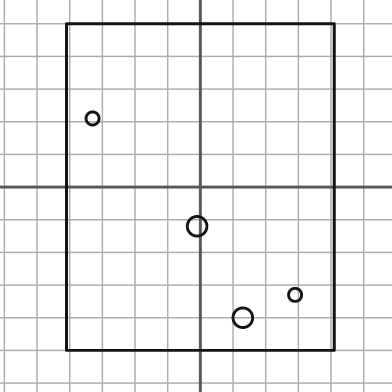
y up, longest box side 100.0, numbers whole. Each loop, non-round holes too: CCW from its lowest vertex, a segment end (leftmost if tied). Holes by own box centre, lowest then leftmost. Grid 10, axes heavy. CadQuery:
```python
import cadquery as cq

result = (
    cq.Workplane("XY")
    .moveTo(-41.0, -50.0)
    .lineTo(41.0, -50.0)
    .lineTo(41.0, 50.0)
    .lineTo(-41.0, 50.0)
    .close()
    .moveTo(13.0, -40.0)
    .circle(3.0)
    .moveTo(29.0, -33.0)
    .circle(2.0)
    .moveTo(-1.0, -12.0)
    .circle(3.0)
    .moveTo(-33.0, 21.0)
    .circle(2.0)
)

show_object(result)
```